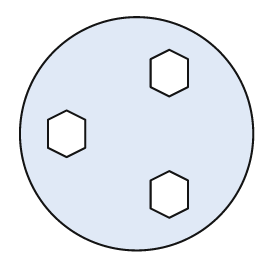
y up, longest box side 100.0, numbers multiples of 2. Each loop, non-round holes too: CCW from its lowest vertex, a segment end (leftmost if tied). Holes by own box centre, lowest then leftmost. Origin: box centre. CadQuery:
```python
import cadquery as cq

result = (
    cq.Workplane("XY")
    .moveTo(0.0, 0.0)
    .circle(50.0)
    .moveTo(14.0, -36.0)
    .lineTo(22.0, -32.0)
    .lineTo(22.0, -20.0)
    .lineTo(14.0, -16.0)
    .lineTo(6.0, -20.0)
    .lineTo(6.0, -32.0)
    .close()
    .moveTo(-30.0, -10.0)
    .lineTo(-22.0, -6.0)
    .lineTo(-22.0, 6.0)
    .lineTo(-30.0, 10.0)
    .lineTo(-38.0, 6.0)
    .lineTo(-38.0, -6.0)
    .close()
    .moveTo(14.0, 16.0)
    .lineTo(22.0, 20.0)
    .lineTo(22.0, 32.0)
    .lineTo(14.0, 36.0)
    .lineTo(6.0, 32.0)
    .lineTo(6.0, 20.0)
    .close()
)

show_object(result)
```